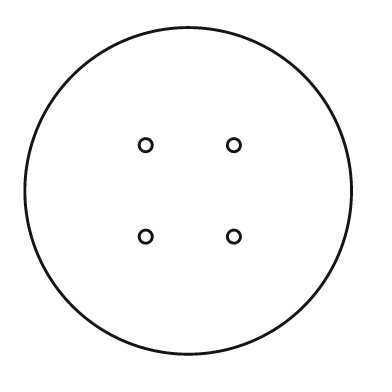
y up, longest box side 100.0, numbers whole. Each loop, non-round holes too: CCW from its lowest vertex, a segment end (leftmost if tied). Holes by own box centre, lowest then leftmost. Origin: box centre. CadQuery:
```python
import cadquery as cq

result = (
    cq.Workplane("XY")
    .moveTo(0.0, 0.0)
    .circle(50.0)
    .moveTo(-13.0, -14.0)
    .circle(2.0)
    .moveTo(14.0, -14.0)
    .circle(2.0)
    .moveTo(-13.0, 14.0)
    .circle(2.0)
    .moveTo(14.0, 14.0)
    .circle(2.0)
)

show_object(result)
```